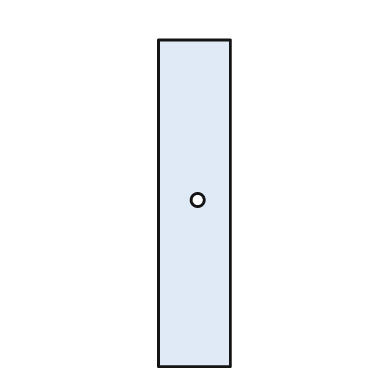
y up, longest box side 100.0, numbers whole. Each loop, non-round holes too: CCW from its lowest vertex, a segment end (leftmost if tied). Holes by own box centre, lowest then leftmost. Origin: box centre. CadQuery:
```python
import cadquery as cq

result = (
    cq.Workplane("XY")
    .moveTo(-11.0, -50.0)
    .lineTo(11.0, -50.0)
    .lineTo(11.0, 50.0)
    .lineTo(-11.0, 50.0)
    .close()
    .moveTo(1.0, 1.0)
    .circle(2.0)
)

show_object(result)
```